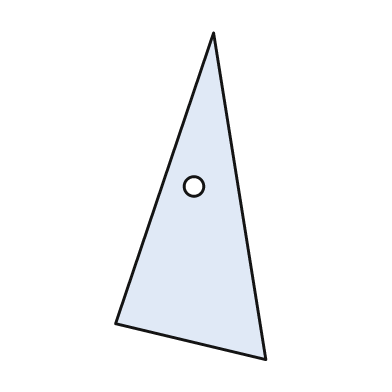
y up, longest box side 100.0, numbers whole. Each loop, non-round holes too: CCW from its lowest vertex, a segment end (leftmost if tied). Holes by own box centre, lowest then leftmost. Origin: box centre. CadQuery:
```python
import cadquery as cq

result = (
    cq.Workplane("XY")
    .moveTo(23.0, -50.0)
    .lineTo(7.0, 50.0)
    .lineTo(-23.0, -39.0)
    .close()
    .moveTo(1.0, 3.0)
    .circle(3.0)
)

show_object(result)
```